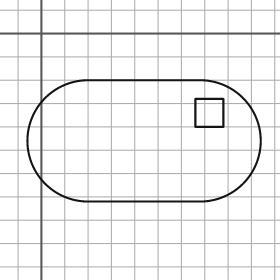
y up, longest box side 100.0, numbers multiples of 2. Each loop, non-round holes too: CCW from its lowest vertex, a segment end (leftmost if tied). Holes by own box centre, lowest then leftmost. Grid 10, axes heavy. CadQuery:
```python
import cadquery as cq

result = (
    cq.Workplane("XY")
    .moveTo(20.0, -72.0)
    .lineTo(68.0, -72.0)
    .threePointArc((94.0, -46.0), (68.0, -20.0))
    .lineTo(20.0, -20.0)
    .threePointArc((-6.0, -46.0), (20.0, -72.0))
    .close()
    .moveTo(66.0, -40.0)
    .lineTo(78.0, -40.0)
    .lineTo(78.0, -28.0)
    .lineTo(66.0, -28.0)
    .close()
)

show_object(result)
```